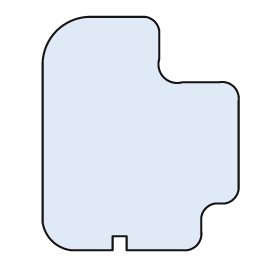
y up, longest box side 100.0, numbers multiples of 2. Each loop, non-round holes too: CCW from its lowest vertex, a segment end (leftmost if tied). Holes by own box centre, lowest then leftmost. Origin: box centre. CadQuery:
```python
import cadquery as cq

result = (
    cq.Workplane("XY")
    .moveTo(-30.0, -50.0)
    .lineTo(-12.0, -50.0)
    .lineTo(-12.0, -44.0)
    .lineTo(-6.0, -44.0)
    .lineTo(-6.0, -50.0)
    .lineTo(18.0, -50.0)
    .threePointArc((24.0, -48.0), (26.0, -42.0))
    .lineTo(26.0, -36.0)
    .threePointArc((28.0, -32.0), (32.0, -30.0))
    .lineTo(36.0, -30.0)
    .threePointArc((40.0, -28.0), (42.0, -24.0))
    .lineTo(42.0, 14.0)
    .threePointArc((40.0, 20.0), (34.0, 22.0))
    .lineTo(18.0, 22.0)
    .threePointArc((10.0, 24.0), (8.0, 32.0))
    .lineTo(8.0, 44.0)
    .threePointArc((6.0, 48.0), (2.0, 50.0))
    .lineTo(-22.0, 50.0)
    .threePointArc((-36.0, 44.0), (-42.0, 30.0))
    .lineTo(-42.0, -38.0)
    .threePointArc((-38.0, -46.0), (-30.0, -50.0))
    .close()
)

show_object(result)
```